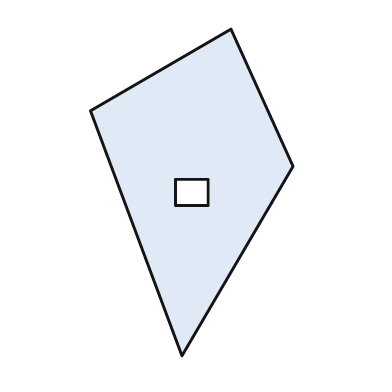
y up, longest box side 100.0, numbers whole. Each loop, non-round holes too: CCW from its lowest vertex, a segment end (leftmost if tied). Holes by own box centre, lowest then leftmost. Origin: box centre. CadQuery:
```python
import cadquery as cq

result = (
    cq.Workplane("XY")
    .moveTo(-3.0, -50.0)
    .lineTo(31.0, 8.0)
    .lineTo(12.0, 50.0)
    .lineTo(-31.0, 25.0)
    .close()
    .moveTo(-5.0, -4.0)
    .lineTo(5.0, -4.0)
    .lineTo(5.0, 4.0)
    .lineTo(-5.0, 4.0)
    .close()
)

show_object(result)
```